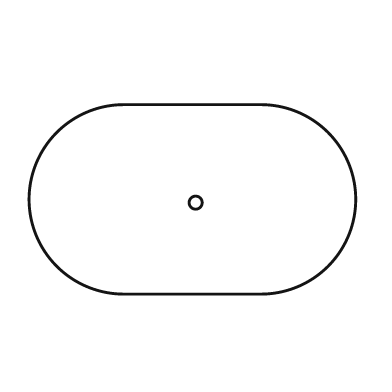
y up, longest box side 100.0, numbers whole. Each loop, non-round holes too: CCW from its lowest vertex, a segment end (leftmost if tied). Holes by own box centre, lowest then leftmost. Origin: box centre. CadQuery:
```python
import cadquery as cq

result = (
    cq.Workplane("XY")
    .moveTo(-21.0, -29.0)
    .lineTo(21.0, -29.0)
    .threePointArc((50.0, 0.0), (21.0, 29.0))
    .lineTo(-21.0, 29.0)
    .threePointArc((-50.0, 0.0), (-21.0, -29.0))
    .close()
    .moveTo(1.0, -1.0)
    .circle(2.0)
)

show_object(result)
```